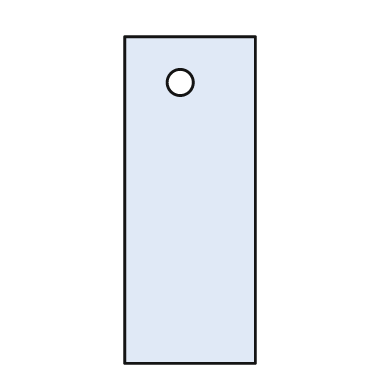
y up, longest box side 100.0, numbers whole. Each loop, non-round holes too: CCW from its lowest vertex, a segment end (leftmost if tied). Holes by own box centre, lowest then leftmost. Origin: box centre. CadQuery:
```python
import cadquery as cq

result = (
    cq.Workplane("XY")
    .moveTo(-20.0, -50.0)
    .lineTo(20.0, -50.0)
    .lineTo(20.0, 50.0)
    .lineTo(-20.0, 50.0)
    .close()
    .moveTo(-3.0, 36.0)
    .circle(4.0)
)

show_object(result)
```